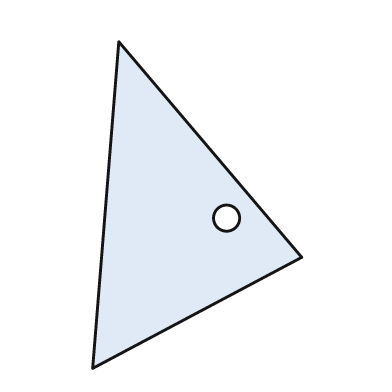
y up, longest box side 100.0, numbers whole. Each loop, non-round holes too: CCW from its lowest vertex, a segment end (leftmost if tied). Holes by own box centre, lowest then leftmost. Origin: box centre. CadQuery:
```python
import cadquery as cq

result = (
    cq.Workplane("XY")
    .moveTo(-32.0, -50.0)
    .lineTo(32.0, -16.0)
    .lineTo(-24.0, 50.0)
    .close()
    .moveTo(9.0, -4.0)
    .circle(4.0)
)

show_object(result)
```